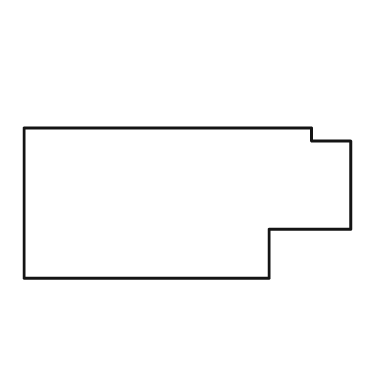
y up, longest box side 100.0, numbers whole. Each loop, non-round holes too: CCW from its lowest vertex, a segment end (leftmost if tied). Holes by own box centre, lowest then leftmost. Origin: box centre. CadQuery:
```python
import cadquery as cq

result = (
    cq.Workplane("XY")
    .moveTo(-50.0, -23.0)
    .lineTo(25.0, -23.0)
    .lineTo(25.0, -8.0)
    .lineTo(50.0, -8.0)
    .lineTo(50.0, 19.0)
    .lineTo(38.0, 19.0)
    .lineTo(38.0, 23.0)
    .lineTo(-50.0, 23.0)
    .close()
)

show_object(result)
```